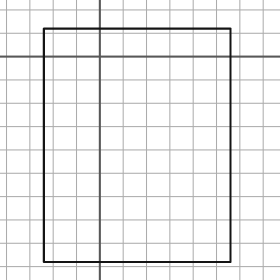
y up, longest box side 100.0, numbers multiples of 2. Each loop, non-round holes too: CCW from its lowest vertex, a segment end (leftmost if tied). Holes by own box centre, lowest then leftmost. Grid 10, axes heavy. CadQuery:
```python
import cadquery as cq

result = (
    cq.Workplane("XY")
    .moveTo(-24.0, -88.0)
    .lineTo(56.0, -88.0)
    .lineTo(56.0, 12.0)
    .lineTo(-24.0, 12.0)
    .close()
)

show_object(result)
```